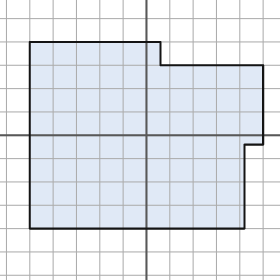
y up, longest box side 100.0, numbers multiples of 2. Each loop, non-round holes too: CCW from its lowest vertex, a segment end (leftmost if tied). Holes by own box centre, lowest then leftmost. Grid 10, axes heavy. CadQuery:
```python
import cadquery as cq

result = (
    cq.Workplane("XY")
    .moveTo(-50.0, -40.0)
    .lineTo(42.0, -40.0)
    .lineTo(42.0, -4.0)
    .lineTo(50.0, -4.0)
    .lineTo(50.0, 30.0)
    .lineTo(6.0, 30.0)
    .lineTo(6.0, 40.0)
    .lineTo(-50.0, 40.0)
    .close()
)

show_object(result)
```